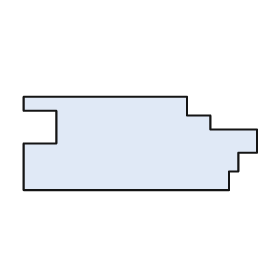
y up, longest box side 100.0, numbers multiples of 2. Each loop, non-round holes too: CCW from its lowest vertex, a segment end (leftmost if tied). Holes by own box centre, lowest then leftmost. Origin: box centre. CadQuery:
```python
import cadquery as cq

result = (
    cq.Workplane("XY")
    .moveTo(-50.0, -20.0)
    .lineTo(38.0, -20.0)
    .lineTo(38.0, -12.0)
    .lineTo(42.0, -12.0)
    .lineTo(42.0, -4.0)
    .lineTo(50.0, -4.0)
    .lineTo(50.0, 6.0)
    .lineTo(30.0, 6.0)
    .lineTo(30.0, 12.0)
    .lineTo(20.0, 12.0)
    .lineTo(20.0, 20.0)
    .lineTo(-50.0, 20.0)
    .lineTo(-50.0, 14.0)
    .lineTo(-36.0, 14.0)
    .lineTo(-36.0, 0.0)
    .lineTo(-50.0, 0.0)
    .close()
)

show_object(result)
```